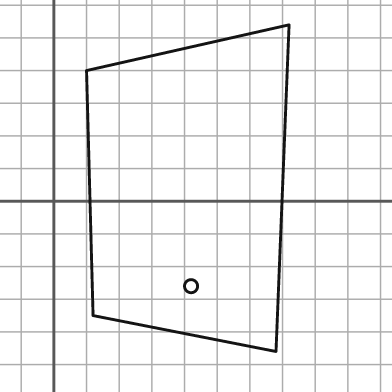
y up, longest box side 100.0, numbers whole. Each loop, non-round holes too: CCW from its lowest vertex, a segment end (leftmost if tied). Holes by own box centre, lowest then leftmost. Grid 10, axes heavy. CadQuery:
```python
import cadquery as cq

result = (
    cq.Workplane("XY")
    .moveTo(68.0, -46.0)
    .lineTo(72.0, 54.0)
    .lineTo(10.0, 40.0)
    .lineTo(12.0, -35.0)
    .close()
    .moveTo(42.0, -26.0)
    .circle(2.0)
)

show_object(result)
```